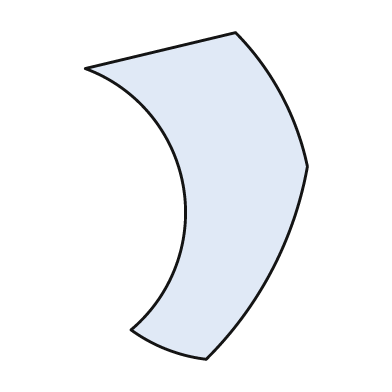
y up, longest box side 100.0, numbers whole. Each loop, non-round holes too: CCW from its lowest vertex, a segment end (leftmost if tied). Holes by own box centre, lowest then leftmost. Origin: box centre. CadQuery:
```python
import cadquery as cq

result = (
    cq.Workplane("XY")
    .moveTo(3.0, -50.0)
    .threePointArc((23.0, -23.0), (34.0, 9.0))
    .threePointArc((26.0, 31.0), (12.0, 50.0))
    .lineTo(-34.0, 39.0)
    .threePointArc((-4.0, 3.0), (-20.0, -41.0))
    .threePointArc((-9.0, -47.0), (3.0, -50.0))
    .close()
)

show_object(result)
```